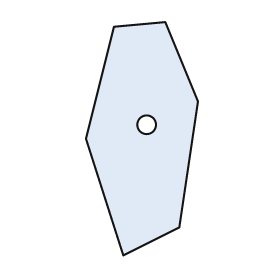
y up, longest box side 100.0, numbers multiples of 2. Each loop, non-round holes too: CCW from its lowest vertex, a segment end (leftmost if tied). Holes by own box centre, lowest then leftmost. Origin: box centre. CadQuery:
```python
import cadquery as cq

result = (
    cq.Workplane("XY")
    .moveTo(-8.0, -50.0)
    .lineTo(16.0, -38.0)
    .lineTo(24.0, 16.0)
    .lineTo(10.0, 50.0)
    .lineTo(-12.0, 48.0)
    .lineTo(-24.0, 0.0)
    .close()
    .moveTo(2.0, 6.0)
    .circle(4.0)
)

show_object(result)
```